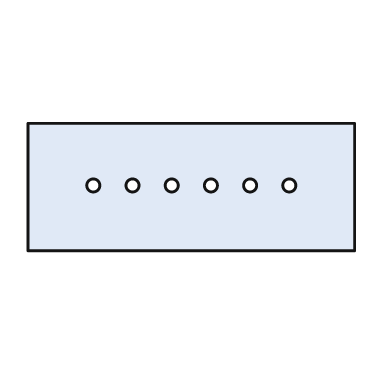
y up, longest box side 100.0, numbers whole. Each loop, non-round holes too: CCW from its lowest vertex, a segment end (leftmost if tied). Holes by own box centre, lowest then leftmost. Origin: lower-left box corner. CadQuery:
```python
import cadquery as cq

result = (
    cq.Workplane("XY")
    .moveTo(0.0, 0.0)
    .lineTo(100.0, 0.0)
    .lineTo(100.0, 39.0)
    .lineTo(0.0, 39.0)
    .close()
    .moveTo(20.0, 20.0)
    .circle(2.0)
    .moveTo(32.0, 20.0)
    .circle(2.0)
    .moveTo(44.0, 20.0)
    .circle(2.0)
    .moveTo(56.0, 20.0)
    .circle(2.0)
    .moveTo(68.0, 20.0)
    .circle(2.0)
    .moveTo(80.0, 20.0)
    .circle(2.0)
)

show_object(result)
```